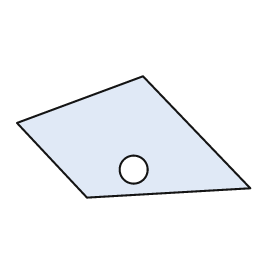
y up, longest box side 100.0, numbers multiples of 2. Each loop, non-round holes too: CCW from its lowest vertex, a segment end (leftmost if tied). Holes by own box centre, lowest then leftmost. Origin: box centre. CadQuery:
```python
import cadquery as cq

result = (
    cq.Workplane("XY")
    .moveTo(-20.0, -26.0)
    .lineTo(50.0, -22.0)
    .lineTo(4.0, 26.0)
    .lineTo(-50.0, 6.0)
    .close()
    .moveTo(0.0, -14.0)
    .circle(6.0)
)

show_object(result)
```